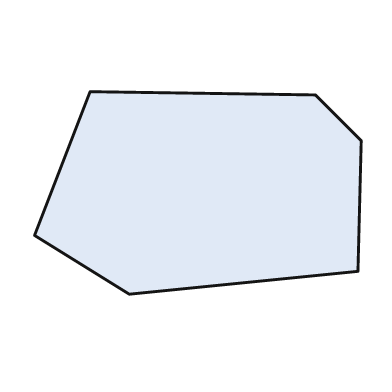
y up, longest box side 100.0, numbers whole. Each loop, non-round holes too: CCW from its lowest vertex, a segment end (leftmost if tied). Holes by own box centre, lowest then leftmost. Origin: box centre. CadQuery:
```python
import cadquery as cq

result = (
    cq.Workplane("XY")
    .moveTo(-21.0, -31.0)
    .lineTo(49.0, -24.0)
    .lineTo(50.0, 16.0)
    .lineTo(36.0, 30.0)
    .lineTo(-33.0, 31.0)
    .lineTo(-50.0, -13.0)
    .close()
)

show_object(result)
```